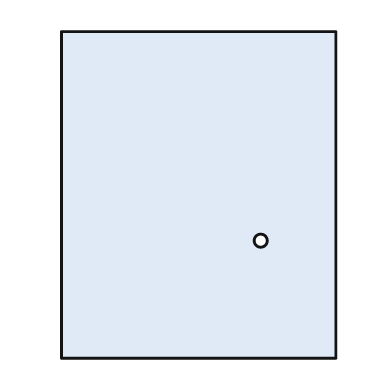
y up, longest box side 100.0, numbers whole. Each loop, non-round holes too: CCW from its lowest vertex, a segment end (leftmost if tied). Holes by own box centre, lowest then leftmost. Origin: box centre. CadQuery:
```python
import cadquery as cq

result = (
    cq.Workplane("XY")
    .moveTo(-42.0, -50.0)
    .lineTo(42.0, -50.0)
    .lineTo(42.0, 50.0)
    .lineTo(-42.0, 50.0)
    .close()
    .moveTo(19.0, -14.0)
    .circle(2.0)
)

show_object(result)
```